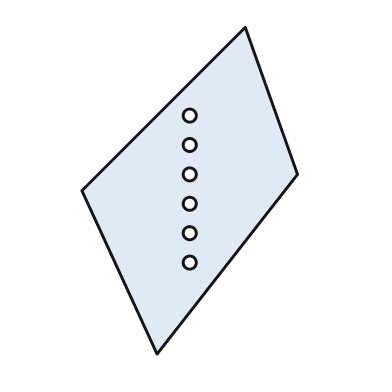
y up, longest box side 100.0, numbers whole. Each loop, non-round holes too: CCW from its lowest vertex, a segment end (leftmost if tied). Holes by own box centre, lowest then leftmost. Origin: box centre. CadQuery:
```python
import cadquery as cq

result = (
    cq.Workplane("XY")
    .moveTo(-10.0, -50.0)
    .lineTo(33.0, 5.0)
    .lineTo(17.0, 50.0)
    .lineTo(-33.0, 0.0)
    .close()
    .moveTo(0.0, -22.0)
    .circle(2.0)
    .moveTo(0.0, -13.0)
    .circle(2.0)
    .moveTo(0.0, -4.0)
    .circle(2.0)
    .moveTo(0.0, 5.0)
    .circle(2.0)
    .moveTo(0.0, 14.0)
    .circle(2.0)
    .moveTo(0.0, 23.0)
    .circle(2.0)
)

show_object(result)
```